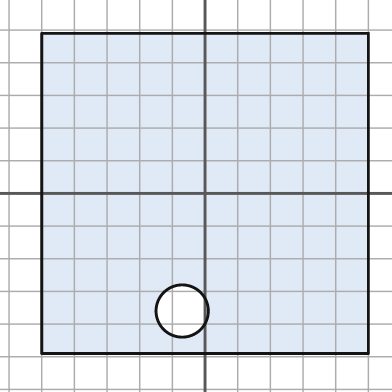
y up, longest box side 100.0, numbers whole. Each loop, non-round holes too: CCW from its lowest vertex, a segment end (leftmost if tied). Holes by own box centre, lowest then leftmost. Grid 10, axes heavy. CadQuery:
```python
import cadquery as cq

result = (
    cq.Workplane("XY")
    .moveTo(-50.0, -49.0)
    .lineTo(50.0, -49.0)
    .lineTo(50.0, 49.0)
    .lineTo(-50.0, 49.0)
    .close()
    .moveTo(-7.0, -36.0)
    .circle(8.0)
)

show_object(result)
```